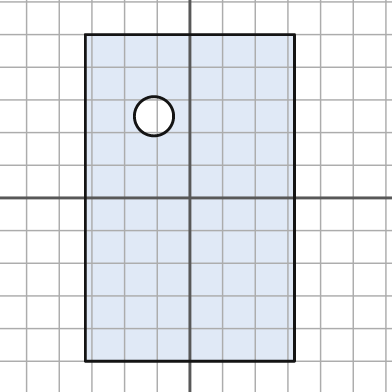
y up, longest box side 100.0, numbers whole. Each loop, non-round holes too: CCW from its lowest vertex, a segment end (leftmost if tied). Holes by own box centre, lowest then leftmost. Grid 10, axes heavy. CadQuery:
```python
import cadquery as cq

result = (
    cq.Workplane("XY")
    .moveTo(-32.0, -50.0)
    .lineTo(32.0, -50.0)
    .lineTo(32.0, 50.0)
    .lineTo(-32.0, 50.0)
    .close()
    .moveTo(-11.0, 25.0)
    .circle(6.0)
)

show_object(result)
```